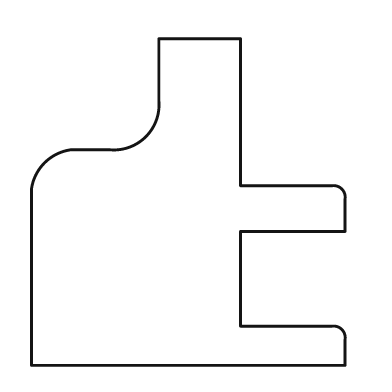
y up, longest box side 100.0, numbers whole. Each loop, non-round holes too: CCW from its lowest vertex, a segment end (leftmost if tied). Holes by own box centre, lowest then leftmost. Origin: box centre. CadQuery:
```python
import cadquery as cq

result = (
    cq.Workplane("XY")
    .moveTo(-48.0, -50.0)
    .lineTo(48.0, -50.0)
    .lineTo(48.0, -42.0)
    .threePointArc((47.0, -39.0), (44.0, -38.0))
    .lineTo(16.0, -38.0)
    .lineTo(16.0, -9.0)
    .lineTo(48.0, -9.0)
    .lineTo(48.0, 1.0)
    .threePointArc((47.0, 4.0), (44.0, 5.0))
    .lineTo(16.0, 5.0)
    .lineTo(16.0, 50.0)
    .lineTo(-9.0, 50.0)
    .lineTo(-9.0, 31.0)
    .threePointArc((-13.0, 20.0), (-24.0, 16.0))
    .lineTo(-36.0, 16.0)
    .threePointArc((-44.0, 12.0), (-48.0, 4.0))
    .close()
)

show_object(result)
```